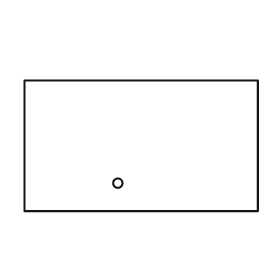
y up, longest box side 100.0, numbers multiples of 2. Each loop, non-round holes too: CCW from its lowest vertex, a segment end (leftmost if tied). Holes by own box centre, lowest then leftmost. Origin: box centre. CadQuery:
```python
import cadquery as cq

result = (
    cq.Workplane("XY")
    .moveTo(-50.0, -28.0)
    .lineTo(50.0, -28.0)
    .lineTo(50.0, 28.0)
    .lineTo(-50.0, 28.0)
    .close()
    .moveTo(-10.0, -16.0)
    .circle(2.0)
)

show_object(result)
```